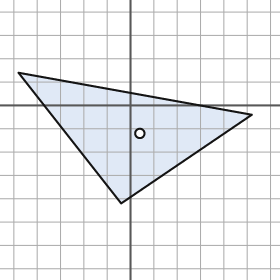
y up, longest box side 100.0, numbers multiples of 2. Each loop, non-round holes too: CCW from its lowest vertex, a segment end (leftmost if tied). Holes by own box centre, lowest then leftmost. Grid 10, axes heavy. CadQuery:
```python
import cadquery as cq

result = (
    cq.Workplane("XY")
    .moveTo(-4.0, -42.0)
    .lineTo(52.0, -4.0)
    .lineTo(-48.0, 14.0)
    .close()
    .moveTo(4.0, -12.0)
    .circle(2.0)
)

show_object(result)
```